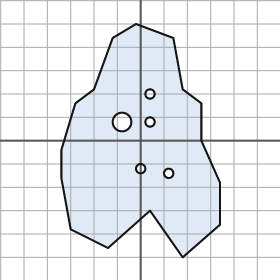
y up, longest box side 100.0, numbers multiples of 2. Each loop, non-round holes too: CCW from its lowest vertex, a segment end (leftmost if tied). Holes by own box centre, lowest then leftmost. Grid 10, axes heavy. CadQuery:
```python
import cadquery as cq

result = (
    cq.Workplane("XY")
    .moveTo(18.0, -50.0)
    .lineTo(34.0, -36.0)
    .lineTo(34.0, -18.0)
    .lineTo(26.0, 0.0)
    .lineTo(26.0, 16.0)
    .lineTo(18.0, 22.0)
    .lineTo(14.0, 44.0)
    .lineTo(-2.0, 50.0)
    .lineTo(-12.0, 44.0)
    .lineTo(-20.0, 22.0)
    .lineTo(-28.0, 16.0)
    .lineTo(-34.0, -4.0)
    .lineTo(-34.0, -16.0)
    .lineTo(-30.0, -38.0)
    .lineTo(-14.0, -46.0)
    .lineTo(4.0, -30.0)
    .close()
    .moveTo(12.0, -14.0)
    .circle(2.0)
    .moveTo(0.0, -12.0)
    .circle(2.0)
    .moveTo(-8.0, 8.0)
    .circle(4.0)
    .moveTo(4.0, 8.0)
    .circle(2.0)
    .moveTo(4.0, 20.0)
    .circle(2.0)
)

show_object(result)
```